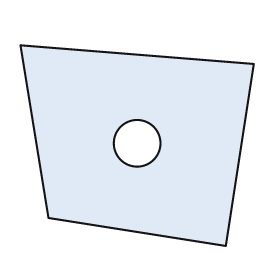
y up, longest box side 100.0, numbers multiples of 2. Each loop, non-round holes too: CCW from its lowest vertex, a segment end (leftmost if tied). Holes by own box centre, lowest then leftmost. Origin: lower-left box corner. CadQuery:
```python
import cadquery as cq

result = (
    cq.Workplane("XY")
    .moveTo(88.0, 0.0)
    .lineTo(100.0, 78.0)
    .lineTo(0.0, 86.0)
    .lineTo(12.0, 12.0)
    .close()
    .moveTo(50.0, 44.0)
    .circle(10.0)
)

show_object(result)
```